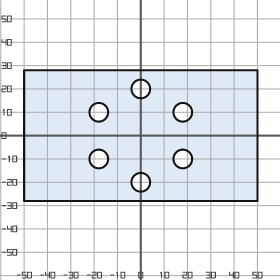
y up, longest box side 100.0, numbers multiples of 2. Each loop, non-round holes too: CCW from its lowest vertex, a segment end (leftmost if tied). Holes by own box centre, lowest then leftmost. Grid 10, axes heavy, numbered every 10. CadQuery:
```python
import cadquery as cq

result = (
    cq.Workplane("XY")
    .moveTo(-50.0, -28.0)
    .lineTo(50.0, -28.0)
    .lineTo(50.0, 28.0)
    .lineTo(-50.0, 28.0)
    .close()
    .moveTo(0.0, -20.0)
    .circle(4.0)
    .moveTo(-18.0, -10.0)
    .circle(4.0)
    .moveTo(18.0, -10.0)
    .circle(4.0)
    .moveTo(-18.0, 10.0)
    .circle(4.0)
    .moveTo(18.0, 10.0)
    .circle(4.0)
    .moveTo(0.0, 20.0)
    .circle(4.0)
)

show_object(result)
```